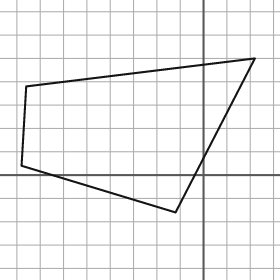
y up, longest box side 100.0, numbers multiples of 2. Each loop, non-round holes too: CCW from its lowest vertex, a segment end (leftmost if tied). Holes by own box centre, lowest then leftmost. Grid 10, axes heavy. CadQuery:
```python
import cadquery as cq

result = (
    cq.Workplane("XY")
    .moveTo(-12.0, -16.0)
    .lineTo(22.0, 50.0)
    .lineTo(-76.0, 38.0)
    .lineTo(-78.0, 4.0)
    .close()
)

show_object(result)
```